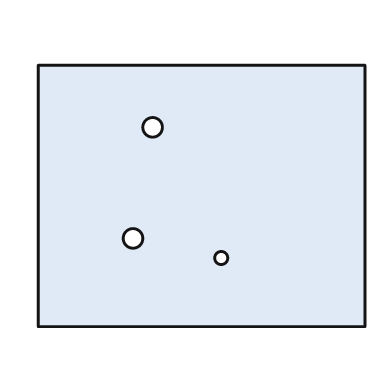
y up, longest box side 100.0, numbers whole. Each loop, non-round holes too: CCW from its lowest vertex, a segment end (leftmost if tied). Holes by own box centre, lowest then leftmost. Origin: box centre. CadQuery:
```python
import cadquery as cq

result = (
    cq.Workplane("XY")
    .moveTo(-50.0, -40.0)
    .lineTo(50.0, -40.0)
    .lineTo(50.0, 40.0)
    .lineTo(-50.0, 40.0)
    .close()
    .moveTo(6.0, -19.0)
    .circle(2.0)
    .moveTo(-21.0, -13.0)
    .circle(3.0)
    .moveTo(-15.0, 21.0)
    .circle(3.0)
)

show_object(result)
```